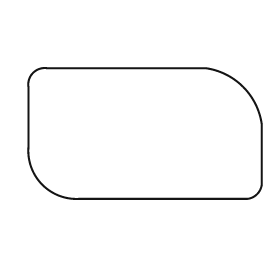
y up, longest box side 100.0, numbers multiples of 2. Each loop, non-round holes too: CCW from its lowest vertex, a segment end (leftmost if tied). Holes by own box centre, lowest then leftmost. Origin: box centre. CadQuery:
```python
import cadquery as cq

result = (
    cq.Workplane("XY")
    .moveTo(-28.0, -28.0)
    .lineTo(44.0, -28.0)
    .threePointArc((48.0, -26.0), (50.0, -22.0))
    .lineTo(50.0, 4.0)
    .threePointArc((42.0, 20.0), (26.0, 28.0))
    .lineTo(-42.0, 28.0)
    .threePointArc((-48.0, 26.0), (-50.0, 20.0))
    .lineTo(-50.0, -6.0)
    .threePointArc((-44.0, -22.0), (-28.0, -28.0))
    .close()
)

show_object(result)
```